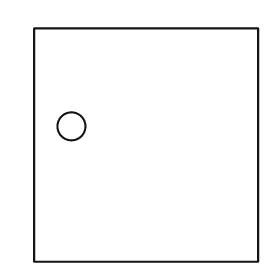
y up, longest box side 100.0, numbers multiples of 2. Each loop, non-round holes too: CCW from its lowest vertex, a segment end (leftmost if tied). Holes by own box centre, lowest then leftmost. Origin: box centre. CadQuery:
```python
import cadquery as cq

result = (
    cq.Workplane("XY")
    .moveTo(-48.0, -50.0)
    .lineTo(48.0, -50.0)
    .lineTo(48.0, 50.0)
    .lineTo(-48.0, 50.0)
    .close()
    .moveTo(-32.0, 8.0)
    .circle(6.0)
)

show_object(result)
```